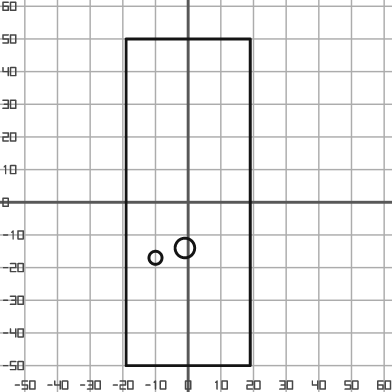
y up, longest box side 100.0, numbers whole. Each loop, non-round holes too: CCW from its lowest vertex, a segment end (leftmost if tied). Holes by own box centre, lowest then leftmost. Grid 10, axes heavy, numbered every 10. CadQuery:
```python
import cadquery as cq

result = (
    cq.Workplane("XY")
    .moveTo(-19.0, -50.0)
    .lineTo(19.0, -50.0)
    .lineTo(19.0, 50.0)
    .lineTo(-19.0, 50.0)
    .close()
    .moveTo(-10.0, -17.0)
    .circle(2.0)
    .moveTo(-1.0, -14.0)
    .circle(3.0)
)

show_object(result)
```